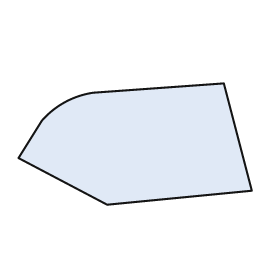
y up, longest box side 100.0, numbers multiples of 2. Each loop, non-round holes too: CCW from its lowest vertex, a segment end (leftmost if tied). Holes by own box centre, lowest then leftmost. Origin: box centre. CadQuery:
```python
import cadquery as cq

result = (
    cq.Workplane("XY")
    .moveTo(-12.0, -26.0)
    .lineTo(50.0, -20.0)
    .lineTo(38.0, 26.0)
    .lineTo(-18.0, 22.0)
    .threePointArc((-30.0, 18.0), (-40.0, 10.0))
    .lineTo(-50.0, -6.0)
    .close()
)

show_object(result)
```